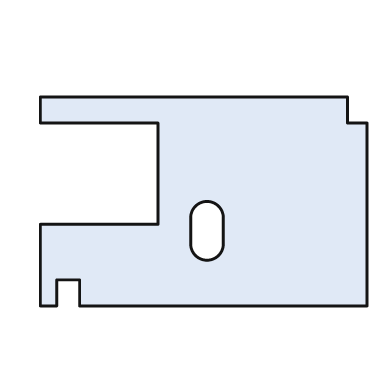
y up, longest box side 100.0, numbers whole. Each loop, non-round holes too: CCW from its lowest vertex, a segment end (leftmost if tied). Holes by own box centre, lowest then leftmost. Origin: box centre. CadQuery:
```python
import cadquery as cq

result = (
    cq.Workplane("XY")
    .moveTo(-50.0, -32.0)
    .lineTo(-45.0, -32.0)
    .lineTo(-45.0, -24.0)
    .lineTo(-38.0, -24.0)
    .lineTo(-38.0, -32.0)
    .lineTo(50.0, -32.0)
    .lineTo(50.0, 24.0)
    .lineTo(44.0, 24.0)
    .lineTo(44.0, 32.0)
    .lineTo(-50.0, 32.0)
    .lineTo(-50.0, 24.0)
    .lineTo(-14.0, 24.0)
    .lineTo(-14.0, -7.0)
    .lineTo(-50.0, -7.0)
    .close()
    .moveTo(-4.0, -13.0)
    .threePointArc((1.0, -18.0), (6.0, -13.0))
    .lineTo(6.0, -5.0)
    .threePointArc((1.0, 0.0), (-4.0, -5.0))
    .close()
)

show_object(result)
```